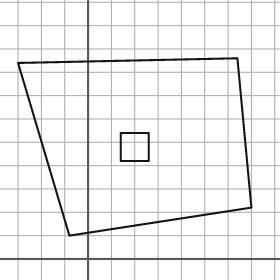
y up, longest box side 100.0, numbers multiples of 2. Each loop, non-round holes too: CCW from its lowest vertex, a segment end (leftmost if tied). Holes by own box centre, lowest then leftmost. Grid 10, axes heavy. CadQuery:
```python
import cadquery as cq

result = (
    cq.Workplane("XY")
    .moveTo(-8.0, 10.0)
    .lineTo(70.0, 22.0)
    .lineTo(64.0, 86.0)
    .lineTo(-30.0, 84.0)
    .close()
    .moveTo(14.0, 42.0)
    .lineTo(26.0, 42.0)
    .lineTo(26.0, 54.0)
    .lineTo(14.0, 54.0)
    .close()
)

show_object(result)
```